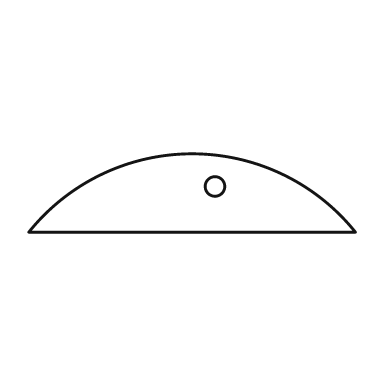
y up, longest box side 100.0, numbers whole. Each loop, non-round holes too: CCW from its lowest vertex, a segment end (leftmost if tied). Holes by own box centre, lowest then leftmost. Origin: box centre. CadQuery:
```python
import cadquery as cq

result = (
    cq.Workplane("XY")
    .moveTo(-50.0, -12.0)
    .lineTo(50.0, -12.0)
    .threePointArc((0.0, 12.0), (-50.0, -12.0))
    .close()
    .moveTo(7.0, 2.0)
    .circle(3.0)
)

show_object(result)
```